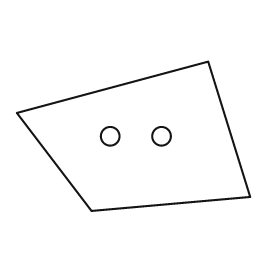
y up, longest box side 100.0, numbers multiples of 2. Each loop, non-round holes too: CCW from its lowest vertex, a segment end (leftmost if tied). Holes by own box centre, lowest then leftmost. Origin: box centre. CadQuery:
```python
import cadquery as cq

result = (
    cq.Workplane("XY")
    .moveTo(-18.0, -32.0)
    .lineTo(50.0, -26.0)
    .lineTo(32.0, 32.0)
    .lineTo(-50.0, 10.0)
    .close()
    .moveTo(-10.0, 0.0)
    .circle(4.0)
    .moveTo(12.0, 0.0)
    .circle(4.0)
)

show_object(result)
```